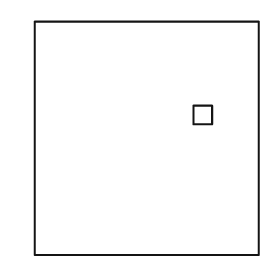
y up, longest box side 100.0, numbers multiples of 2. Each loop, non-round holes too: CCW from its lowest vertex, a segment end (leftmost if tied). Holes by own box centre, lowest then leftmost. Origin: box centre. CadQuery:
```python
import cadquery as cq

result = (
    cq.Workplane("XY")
    .moveTo(-48.0, -50.0)
    .lineTo(48.0, -50.0)
    .lineTo(48.0, 50.0)
    .lineTo(-48.0, 50.0)
    .close()
    .moveTo(20.0, 6.0)
    .lineTo(28.0, 6.0)
    .lineTo(28.0, 14.0)
    .lineTo(20.0, 14.0)
    .close()
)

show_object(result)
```